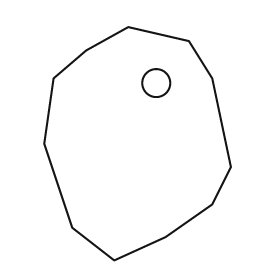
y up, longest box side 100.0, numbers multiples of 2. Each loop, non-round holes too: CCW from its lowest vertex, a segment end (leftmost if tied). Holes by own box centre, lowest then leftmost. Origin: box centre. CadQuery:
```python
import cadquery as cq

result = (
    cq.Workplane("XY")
    .moveTo(-10.0, -50.0)
    .lineTo(12.0, -40.0)
    .lineTo(32.0, -26.0)
    .lineTo(40.0, -10.0)
    .lineTo(32.0, 28.0)
    .lineTo(22.0, 44.0)
    .lineTo(-4.0, 50.0)
    .lineTo(-22.0, 40.0)
    .lineTo(-36.0, 28.0)
    .lineTo(-40.0, 0.0)
    .lineTo(-28.0, -36.0)
    .close()
    .moveTo(8.0, 26.0)
    .circle(6.0)
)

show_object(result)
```